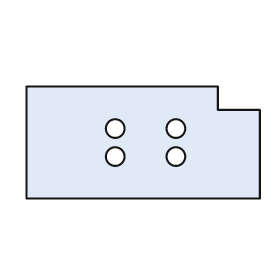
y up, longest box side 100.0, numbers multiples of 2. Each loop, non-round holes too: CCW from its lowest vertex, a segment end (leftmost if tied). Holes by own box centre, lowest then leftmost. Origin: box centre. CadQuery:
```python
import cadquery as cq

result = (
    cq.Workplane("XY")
    .moveTo(-50.0, -24.0)
    .lineTo(50.0, -24.0)
    .lineTo(50.0, 14.0)
    .lineTo(32.0, 14.0)
    .lineTo(32.0, 24.0)
    .lineTo(-50.0, 24.0)
    .close()
    .moveTo(-12.0, -6.0)
    .circle(4.0)
    .moveTo(14.0, -6.0)
    .circle(4.0)
    .moveTo(-12.0, 6.0)
    .circle(4.0)
    .moveTo(14.0, 6.0)
    .circle(4.0)
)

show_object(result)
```